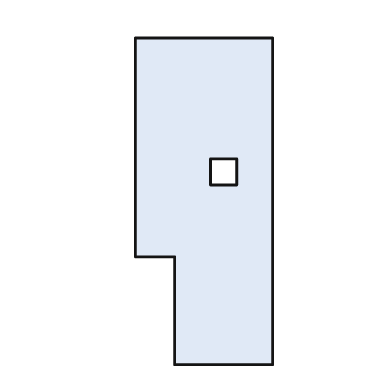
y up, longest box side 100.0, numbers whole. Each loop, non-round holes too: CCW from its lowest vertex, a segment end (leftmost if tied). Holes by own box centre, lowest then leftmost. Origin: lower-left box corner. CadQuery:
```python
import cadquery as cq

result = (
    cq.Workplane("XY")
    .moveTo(12.0, 0.0)
    .lineTo(42.0, 0.0)
    .lineTo(42.0, 100.0)
    .lineTo(0.0, 100.0)
    .lineTo(0.0, 33.0)
    .lineTo(12.0, 33.0)
    .close()
    .moveTo(23.0, 55.0)
    .lineTo(31.0, 55.0)
    .lineTo(31.0, 63.0)
    .lineTo(23.0, 63.0)
    .close()
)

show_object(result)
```